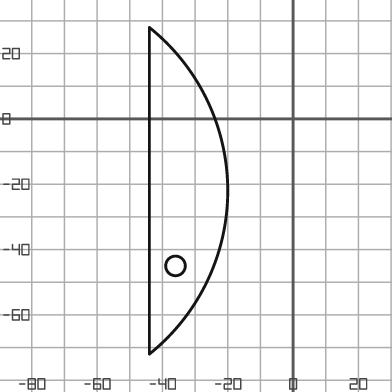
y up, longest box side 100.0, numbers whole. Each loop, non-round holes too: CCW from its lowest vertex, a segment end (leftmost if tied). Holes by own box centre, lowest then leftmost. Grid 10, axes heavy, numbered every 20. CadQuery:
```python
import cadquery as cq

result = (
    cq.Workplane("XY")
    .moveTo(-44.0, -72.0)
    .threePointArc((-20.0, -22.0), (-44.0, 28.0))
    .close()
    .moveTo(-36.0, -45.0)
    .circle(3.0)
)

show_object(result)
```